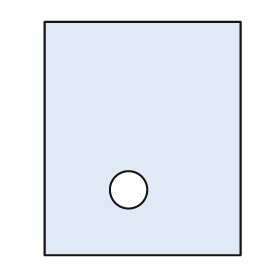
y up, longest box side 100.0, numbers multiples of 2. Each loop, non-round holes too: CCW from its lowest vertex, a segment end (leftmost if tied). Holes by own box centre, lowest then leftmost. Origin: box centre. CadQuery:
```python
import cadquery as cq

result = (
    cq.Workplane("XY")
    .moveTo(-42.0, -50.0)
    .lineTo(42.0, -50.0)
    .lineTo(42.0, 50.0)
    .lineTo(-42.0, 50.0)
    .close()
    .moveTo(-6.0, -22.0)
    .circle(8.0)
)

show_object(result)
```